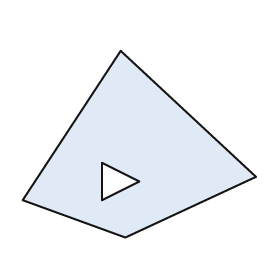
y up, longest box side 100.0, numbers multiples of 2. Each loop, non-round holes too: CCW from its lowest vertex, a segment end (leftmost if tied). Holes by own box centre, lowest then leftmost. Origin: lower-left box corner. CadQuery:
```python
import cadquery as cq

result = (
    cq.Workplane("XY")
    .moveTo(44.0, 0.0)
    .lineTo(100.0, 26.0)
    .lineTo(42.0, 80.0)
    .lineTo(0.0, 16.0)
    .close()
    .moveTo(34.0, 16.0)
    .lineTo(50.0, 24.0)
    .lineTo(34.0, 32.0)
    .close()
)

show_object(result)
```